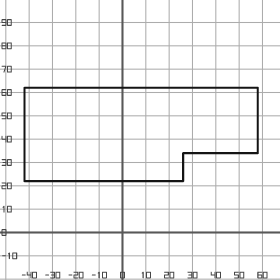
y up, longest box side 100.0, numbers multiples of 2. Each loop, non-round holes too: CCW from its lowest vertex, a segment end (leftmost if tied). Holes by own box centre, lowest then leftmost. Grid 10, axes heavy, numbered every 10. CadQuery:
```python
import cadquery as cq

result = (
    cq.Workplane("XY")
    .moveTo(-42.0, 22.0)
    .lineTo(26.0, 22.0)
    .lineTo(26.0, 34.0)
    .lineTo(58.0, 34.0)
    .lineTo(58.0, 62.0)
    .lineTo(-42.0, 62.0)
    .close()
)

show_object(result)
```